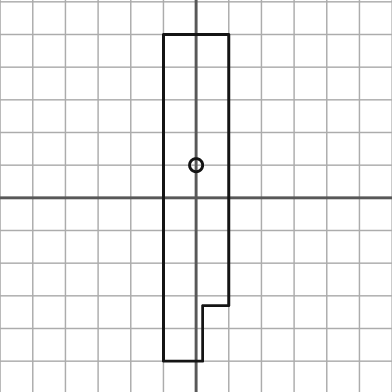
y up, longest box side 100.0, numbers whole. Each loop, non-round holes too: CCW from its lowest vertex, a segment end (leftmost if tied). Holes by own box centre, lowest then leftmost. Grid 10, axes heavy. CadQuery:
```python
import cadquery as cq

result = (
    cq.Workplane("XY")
    .moveTo(-10.0, -50.0)
    .lineTo(2.0, -50.0)
    .lineTo(2.0, -33.0)
    .lineTo(10.0, -33.0)
    .lineTo(10.0, 50.0)
    .lineTo(-10.0, 50.0)
    .close()
    .moveTo(0.0, 10.0)
    .circle(2.0)
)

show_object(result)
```